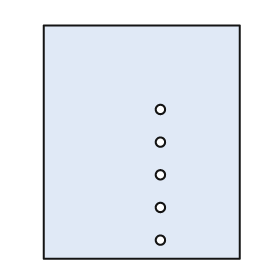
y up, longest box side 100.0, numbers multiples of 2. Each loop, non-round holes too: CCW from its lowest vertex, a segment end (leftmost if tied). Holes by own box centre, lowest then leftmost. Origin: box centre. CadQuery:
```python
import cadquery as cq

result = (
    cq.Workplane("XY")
    .moveTo(-42.0, -50.0)
    .lineTo(42.0, -50.0)
    .lineTo(42.0, 50.0)
    .lineTo(-42.0, 50.0)
    .close()
    .moveTo(8.0, -42.0)
    .circle(2.0)
    .moveTo(8.0, -28.0)
    .circle(2.0)
    .moveTo(8.0, -14.0)
    .circle(2.0)
    .moveTo(8.0, 0.0)
    .circle(2.0)
    .moveTo(8.0, 14.0)
    .circle(2.0)
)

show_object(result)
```